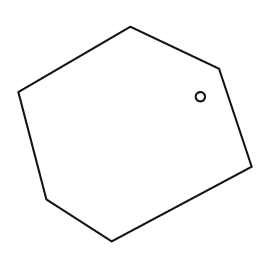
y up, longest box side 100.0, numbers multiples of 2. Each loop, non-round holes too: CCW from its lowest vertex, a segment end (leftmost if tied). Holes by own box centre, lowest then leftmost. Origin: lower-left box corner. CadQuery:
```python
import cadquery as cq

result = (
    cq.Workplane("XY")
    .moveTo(40.0, 0.0)
    .lineTo(100.0, 32.0)
    .lineTo(86.0, 74.0)
    .lineTo(48.0, 92.0)
    .lineTo(0.0, 64.0)
    .lineTo(12.0, 18.0)
    .close()
    .moveTo(78.0, 62.0)
    .circle(2.0)
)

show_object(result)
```